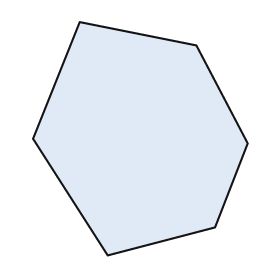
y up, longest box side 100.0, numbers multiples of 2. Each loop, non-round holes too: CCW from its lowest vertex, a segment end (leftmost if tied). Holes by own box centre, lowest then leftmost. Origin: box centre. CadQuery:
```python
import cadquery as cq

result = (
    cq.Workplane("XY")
    .moveTo(-14.0, -50.0)
    .lineTo(32.0, -38.0)
    .lineTo(46.0, -2.0)
    .lineTo(24.0, 40.0)
    .lineTo(-26.0, 50.0)
    .lineTo(-46.0, 0.0)
    .close()
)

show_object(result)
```